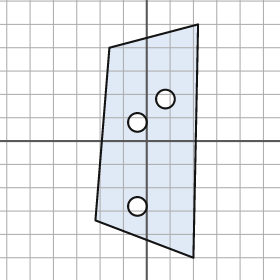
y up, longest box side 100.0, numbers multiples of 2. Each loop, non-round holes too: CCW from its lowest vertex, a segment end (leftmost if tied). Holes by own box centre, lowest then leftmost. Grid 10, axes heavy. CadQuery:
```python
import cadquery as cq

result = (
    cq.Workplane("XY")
    .moveTo(20.0, -50.0)
    .lineTo(22.0, 50.0)
    .lineTo(-16.0, 40.0)
    .lineTo(-22.0, -34.0)
    .close()
    .moveTo(-4.0, -28.0)
    .circle(4.0)
    .moveTo(-4.0, 8.0)
    .circle(4.0)
    .moveTo(8.0, 18.0)
    .circle(4.0)
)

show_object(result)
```